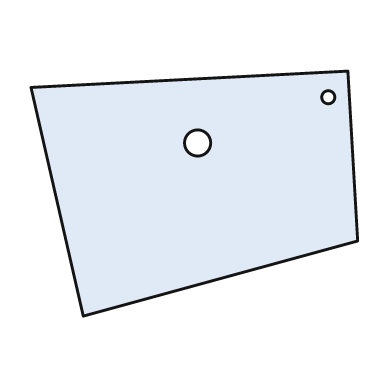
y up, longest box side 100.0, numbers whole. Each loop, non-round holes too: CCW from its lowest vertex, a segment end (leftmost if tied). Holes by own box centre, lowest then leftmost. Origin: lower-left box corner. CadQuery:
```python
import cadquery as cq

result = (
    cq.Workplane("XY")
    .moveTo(16.0, 0.0)
    .lineTo(100.0, 23.0)
    .lineTo(97.0, 75.0)
    .lineTo(0.0, 70.0)
    .close()
    .moveTo(51.0, 53.0)
    .circle(4.0)
    .moveTo(91.0, 67.0)
    .circle(2.0)
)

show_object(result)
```